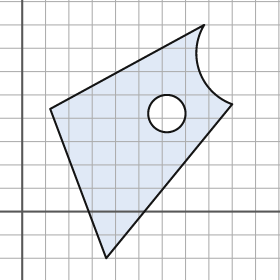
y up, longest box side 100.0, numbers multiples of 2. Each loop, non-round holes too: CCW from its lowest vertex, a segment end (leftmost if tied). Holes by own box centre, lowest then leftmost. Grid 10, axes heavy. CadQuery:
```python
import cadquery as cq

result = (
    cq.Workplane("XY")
    .moveTo(36.0, -20.0)
    .lineTo(90.0, 46.0)
    .threePointArc((76.0, 60.0), (78.0, 80.0))
    .lineTo(12.0, 44.0)
    .close()
    .moveTo(62.0, 42.0)
    .circle(8.0)
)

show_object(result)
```